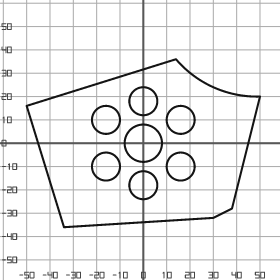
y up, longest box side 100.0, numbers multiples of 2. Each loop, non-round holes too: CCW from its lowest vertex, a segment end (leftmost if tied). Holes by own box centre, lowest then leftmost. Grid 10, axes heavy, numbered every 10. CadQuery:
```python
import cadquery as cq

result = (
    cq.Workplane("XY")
    .moveTo(-34.0, -36.0)
    .lineTo(30.0, -32.0)
    .lineTo(38.0, -28.0)
    .lineTo(50.0, 20.0)
    .threePointArc((30.0, 24.0), (14.0, 36.0))
    .lineTo(-50.0, 16.0)
    .close()
    .moveTo(0.0, -18.0)
    .circle(6.0)
    .moveTo(-16.0, -10.0)
    .circle(6.0)
    .moveTo(16.0, -10.0)
    .circle(6.0)
    .moveTo(0.0, 0.0)
    .circle(8.0)
    .moveTo(-16.0, 10.0)
    .circle(6.0)
    .moveTo(16.0, 10.0)
    .circle(6.0)
    .moveTo(0.0, 18.0)
    .circle(6.0)
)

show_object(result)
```